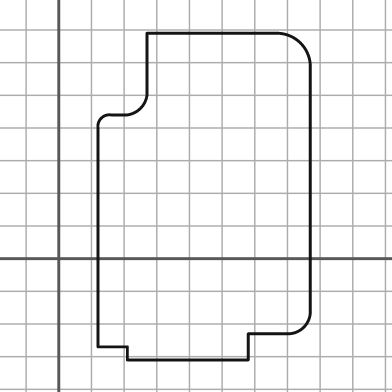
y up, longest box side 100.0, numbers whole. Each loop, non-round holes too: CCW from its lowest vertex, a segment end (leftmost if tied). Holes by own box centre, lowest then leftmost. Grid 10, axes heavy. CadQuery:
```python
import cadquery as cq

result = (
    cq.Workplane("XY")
    .moveTo(21.0, -31.0)
    .lineTo(58.0, -31.0)
    .lineTo(58.0, -23.0)
    .lineTo(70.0, -23.0)
    .threePointArc((75.0, -21.0), (77.0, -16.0))
    .lineTo(77.0, 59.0)
    .threePointArc((74.0, 66.0), (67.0, 69.0))
    .lineTo(27.0, 69.0)
    .lineTo(27.0, 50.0)
    .threePointArc((25.0, 46.0), (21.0, 44.0))
    .lineTo(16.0, 44.0)
    .threePointArc((13.0, 43.0), (12.0, 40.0))
    .lineTo(12.0, -27.0)
    .lineTo(21.0, -27.0)
    .close()
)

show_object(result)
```